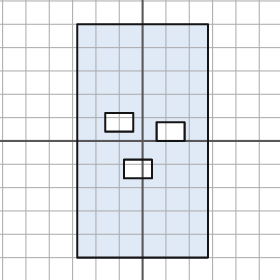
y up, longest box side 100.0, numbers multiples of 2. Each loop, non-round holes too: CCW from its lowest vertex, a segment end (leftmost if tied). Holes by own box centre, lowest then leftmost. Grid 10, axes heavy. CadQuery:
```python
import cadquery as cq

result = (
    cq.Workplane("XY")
    .moveTo(-28.0, -50.0)
    .lineTo(28.0, -50.0)
    .lineTo(28.0, 50.0)
    .lineTo(-28.0, 50.0)
    .close()
    .moveTo(-8.0, -16.0)
    .lineTo(4.0, -16.0)
    .lineTo(4.0, -8.0)
    .lineTo(-8.0, -8.0)
    .close()
    .moveTo(6.0, 0.0)
    .lineTo(18.0, 0.0)
    .lineTo(18.0, 8.0)
    .lineTo(6.0, 8.0)
    .close()
    .moveTo(-16.0, 4.0)
    .lineTo(-4.0, 4.0)
    .lineTo(-4.0, 12.0)
    .lineTo(-16.0, 12.0)
    .close()
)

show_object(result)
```